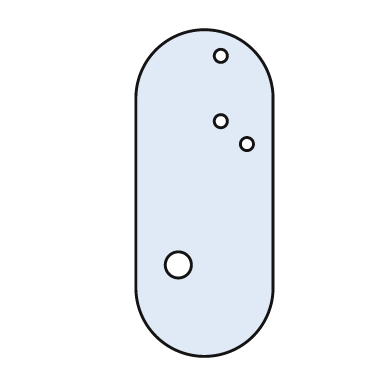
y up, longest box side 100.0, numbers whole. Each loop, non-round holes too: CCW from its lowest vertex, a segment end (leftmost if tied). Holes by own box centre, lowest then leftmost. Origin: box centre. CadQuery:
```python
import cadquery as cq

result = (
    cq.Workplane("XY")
    .moveTo(-21.0, -29.0)
    .threePointArc((0.0, -50.0), (21.0, -29.0))
    .lineTo(21.0, 29.0)
    .threePointArc((0.0, 50.0), (-21.0, 29.0))
    .close()
    .moveTo(-8.0, -22.0)
    .circle(4.0)
    .moveTo(13.0, 15.0)
    .circle(2.0)
    .moveTo(5.0, 22.0)
    .circle(2.0)
    .moveTo(5.0, 42.0)
    .circle(2.0)
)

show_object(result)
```